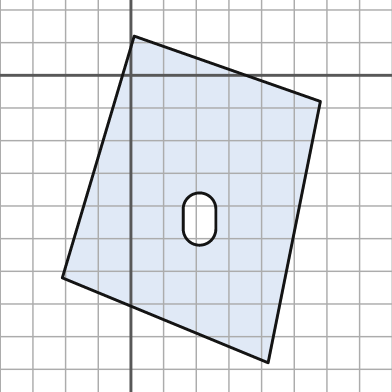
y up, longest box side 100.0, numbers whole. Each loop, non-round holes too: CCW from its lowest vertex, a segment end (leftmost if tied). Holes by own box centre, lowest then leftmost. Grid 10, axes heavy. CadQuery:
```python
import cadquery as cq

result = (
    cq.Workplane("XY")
    .moveTo(42.0, -88.0)
    .lineTo(58.0, -8.0)
    .lineTo(1.0, 12.0)
    .lineTo(-21.0, -62.0)
    .close()
    .moveTo(16.0, -47.0)
    .threePointArc((21.0, -52.0), (26.0, -47.0))
    .lineTo(26.0, -41.0)
    .threePointArc((21.0, -36.0), (16.0, -41.0))
    .close()
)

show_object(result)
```